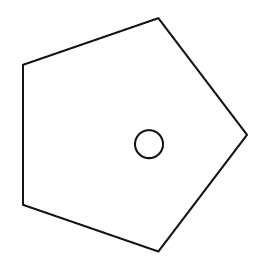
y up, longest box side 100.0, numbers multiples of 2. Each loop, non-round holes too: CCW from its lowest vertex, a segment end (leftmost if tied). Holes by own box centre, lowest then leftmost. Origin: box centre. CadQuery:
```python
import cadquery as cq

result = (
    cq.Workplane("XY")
    .moveTo(10.0, -50.0)
    .lineTo(48.0, 0.0)
    .lineTo(10.0, 50.0)
    .lineTo(-48.0, 30.0)
    .lineTo(-48.0, -30.0)
    .close()
    .moveTo(6.0, -4.0)
    .circle(6.0)
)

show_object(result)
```